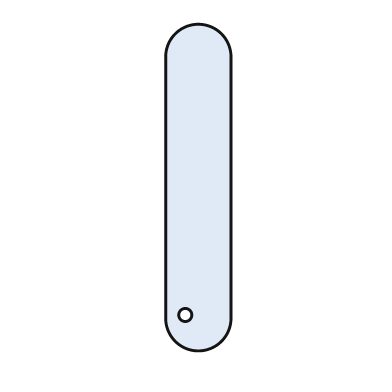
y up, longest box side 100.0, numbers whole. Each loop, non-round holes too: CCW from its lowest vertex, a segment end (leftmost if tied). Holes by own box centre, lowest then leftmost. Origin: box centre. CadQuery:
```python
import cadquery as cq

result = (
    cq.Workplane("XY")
    .moveTo(-10.0, -40.0)
    .threePointArc((0.0, -50.0), (10.0, -40.0))
    .lineTo(10.0, 40.0)
    .threePointArc((0.0, 50.0), (-10.0, 40.0))
    .close()
    .moveTo(-4.0, -39.0)
    .circle(2.0)
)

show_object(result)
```